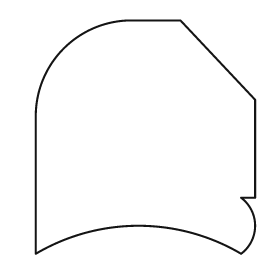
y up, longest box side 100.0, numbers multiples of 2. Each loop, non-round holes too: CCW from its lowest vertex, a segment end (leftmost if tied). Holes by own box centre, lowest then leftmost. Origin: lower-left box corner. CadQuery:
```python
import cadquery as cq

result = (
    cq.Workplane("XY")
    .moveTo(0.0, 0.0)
    .threePointArc((44.0, 12.0), (88.0, 0.0))
    .threePointArc((94.0, 12.0), (88.0, 24.0))
    .lineTo(94.0, 24.0)
    .lineTo(94.0, 66.0)
    .lineTo(62.0, 100.0)
    .lineTo(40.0, 100.0)
    .threePointArc((12.0, 88.0), (0.0, 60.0))
    .close()
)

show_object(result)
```